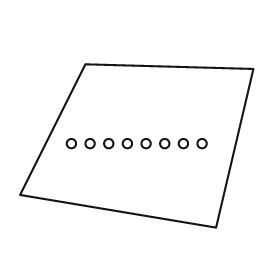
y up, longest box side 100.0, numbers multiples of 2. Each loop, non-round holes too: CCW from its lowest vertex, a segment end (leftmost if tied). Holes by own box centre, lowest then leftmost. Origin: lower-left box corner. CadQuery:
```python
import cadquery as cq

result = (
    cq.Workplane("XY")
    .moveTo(84.0, 0.0)
    .lineTo(100.0, 68.0)
    .lineTo(28.0, 70.0)
    .lineTo(0.0, 14.0)
    .close()
    .moveTo(22.0, 36.0)
    .circle(2.0)
    .moveTo(30.0, 36.0)
    .circle(2.0)
    .moveTo(38.0, 36.0)
    .circle(2.0)
    .moveTo(46.0, 36.0)
    .circle(2.0)
    .moveTo(54.0, 36.0)
    .circle(2.0)
    .moveTo(62.0, 36.0)
    .circle(2.0)
    .moveTo(70.0, 36.0)
    .circle(2.0)
    .moveTo(78.0, 36.0)
    .circle(2.0)
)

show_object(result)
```